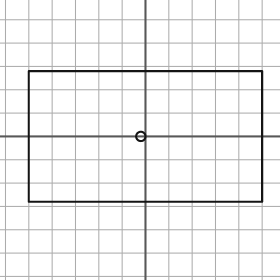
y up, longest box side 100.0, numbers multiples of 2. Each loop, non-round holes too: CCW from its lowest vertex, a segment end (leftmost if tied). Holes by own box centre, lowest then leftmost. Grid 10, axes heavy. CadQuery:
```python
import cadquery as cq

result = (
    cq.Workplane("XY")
    .moveTo(-50.0, -28.0)
    .lineTo(50.0, -28.0)
    .lineTo(50.0, 28.0)
    .lineTo(-50.0, 28.0)
    .close()
    .moveTo(-2.0, 0.0)
    .circle(2.0)
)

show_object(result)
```